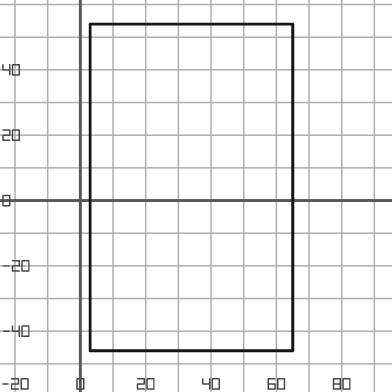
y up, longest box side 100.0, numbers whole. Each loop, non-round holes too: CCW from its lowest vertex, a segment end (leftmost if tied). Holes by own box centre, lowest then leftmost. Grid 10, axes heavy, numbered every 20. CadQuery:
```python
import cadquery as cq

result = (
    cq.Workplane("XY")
    .moveTo(3.0, -46.0)
    .lineTo(65.0, -46.0)
    .lineTo(65.0, 54.0)
    .lineTo(3.0, 54.0)
    .close()
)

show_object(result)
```